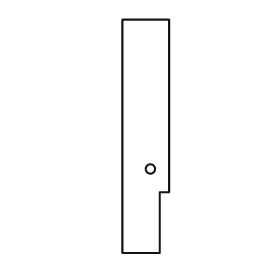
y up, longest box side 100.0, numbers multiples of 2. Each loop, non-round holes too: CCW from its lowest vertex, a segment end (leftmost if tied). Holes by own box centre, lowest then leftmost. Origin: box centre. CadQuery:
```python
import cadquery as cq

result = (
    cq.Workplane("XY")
    .moveTo(-10.0, -50.0)
    .lineTo(6.0, -50.0)
    .lineTo(6.0, -24.0)
    .lineTo(10.0, -24.0)
    .lineTo(10.0, 50.0)
    .lineTo(-10.0, 50.0)
    .close()
    .moveTo(2.0, -14.0)
    .circle(2.0)
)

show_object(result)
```